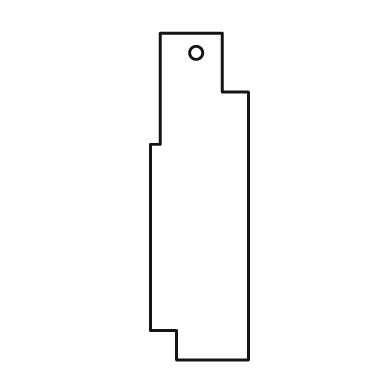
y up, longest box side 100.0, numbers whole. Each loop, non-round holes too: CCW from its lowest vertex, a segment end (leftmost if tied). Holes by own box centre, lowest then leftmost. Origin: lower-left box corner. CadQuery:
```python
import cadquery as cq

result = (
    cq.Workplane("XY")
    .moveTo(8.0, 0.0)
    .lineTo(30.0, 0.0)
    .lineTo(30.0, 82.0)
    .lineTo(22.0, 82.0)
    .lineTo(22.0, 100.0)
    .lineTo(3.0, 100.0)
    .lineTo(3.0, 66.0)
    .lineTo(0.0, 66.0)
    .lineTo(0.0, 9.0)
    .lineTo(8.0, 9.0)
    .close()
    .moveTo(14.0, 94.0)
    .circle(2.0)
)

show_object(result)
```